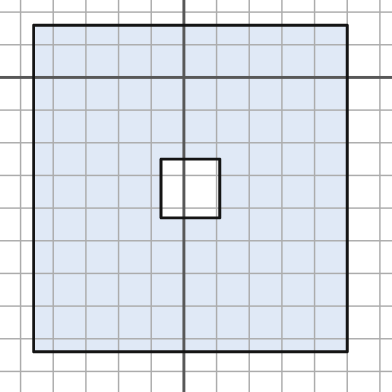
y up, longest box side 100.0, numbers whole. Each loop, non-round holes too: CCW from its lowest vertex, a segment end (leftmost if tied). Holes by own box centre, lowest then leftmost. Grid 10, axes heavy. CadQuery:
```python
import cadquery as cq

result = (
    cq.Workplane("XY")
    .moveTo(-46.0, -84.0)
    .lineTo(50.0, -84.0)
    .lineTo(50.0, 16.0)
    .lineTo(-46.0, 16.0)
    .close()
    .moveTo(-7.0, -43.0)
    .lineTo(11.0, -43.0)
    .lineTo(11.0, -25.0)
    .lineTo(-7.0, -25.0)
    .close()
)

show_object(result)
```